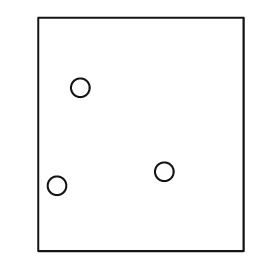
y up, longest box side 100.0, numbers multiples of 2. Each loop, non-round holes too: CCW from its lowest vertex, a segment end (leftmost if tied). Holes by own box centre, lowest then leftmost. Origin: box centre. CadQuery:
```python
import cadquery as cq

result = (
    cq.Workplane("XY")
    .moveTo(-44.0, -50.0)
    .lineTo(44.0, -50.0)
    .lineTo(44.0, 50.0)
    .lineTo(-44.0, 50.0)
    .close()
    .moveTo(-36.0, -22.0)
    .circle(4.0)
    .moveTo(10.0, -16.0)
    .circle(4.0)
    .moveTo(-26.0, 20.0)
    .circle(4.0)
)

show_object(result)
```